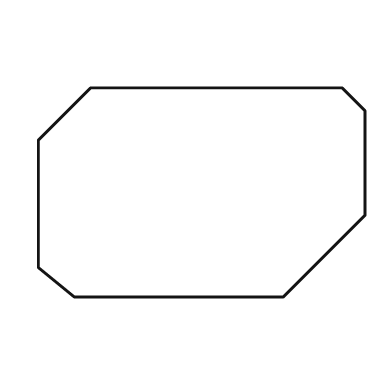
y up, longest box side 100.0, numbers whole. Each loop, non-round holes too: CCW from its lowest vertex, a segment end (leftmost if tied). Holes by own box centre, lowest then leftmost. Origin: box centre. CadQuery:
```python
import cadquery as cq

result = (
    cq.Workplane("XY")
    .moveTo(-39.0, -32.0)
    .lineTo(25.0, -32.0)
    .lineTo(50.0, -7.0)
    .lineTo(50.0, 25.0)
    .lineTo(43.0, 32.0)
    .lineTo(-34.0, 32.0)
    .lineTo(-50.0, 16.0)
    .lineTo(-50.0, -23.0)
    .close()
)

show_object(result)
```